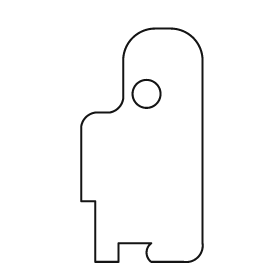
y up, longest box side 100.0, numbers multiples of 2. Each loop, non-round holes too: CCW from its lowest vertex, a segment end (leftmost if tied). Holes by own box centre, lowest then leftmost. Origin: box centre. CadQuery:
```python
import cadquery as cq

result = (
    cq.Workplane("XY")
    .moveTo(-20.0, -50.0)
    .lineTo(-10.0, -50.0)
    .lineTo(-10.0, -42.0)
    .lineTo(4.0, -42.0)
    .threePointArc((2.0, -46.0), (4.0, -50.0))
    .lineTo(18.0, -50.0)
    .threePointArc((24.0, -48.0), (26.0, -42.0))
    .lineTo(26.0, 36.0)
    .threePointArc((22.0, 46.0), (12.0, 50.0))
    .lineTo(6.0, 50.0)
    .threePointArc((-4.0, 46.0), (-8.0, 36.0))
    .lineTo(-8.0, 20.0)
    .threePointArc((-10.0, 16.0), (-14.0, 14.0))
    .lineTo(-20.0, 14.0)
    .threePointArc((-24.0, 12.0), (-26.0, 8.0))
    .lineTo(-26.0, -24.0)
    .lineTo(-20.0, -24.0)
    .close()
    .moveTo(2.0, 22.0)
    .circle(6.0)
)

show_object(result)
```